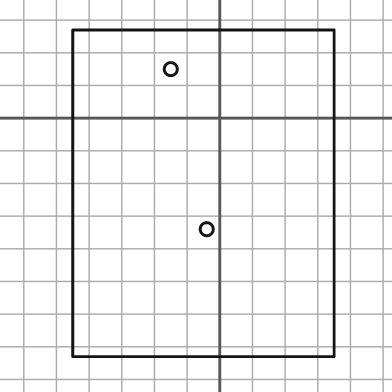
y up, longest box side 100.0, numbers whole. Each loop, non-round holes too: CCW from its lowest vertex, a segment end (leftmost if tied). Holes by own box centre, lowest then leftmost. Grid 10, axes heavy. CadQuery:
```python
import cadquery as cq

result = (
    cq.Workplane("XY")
    .moveTo(-45.0, -73.0)
    .lineTo(35.0, -73.0)
    .lineTo(35.0, 27.0)
    .lineTo(-45.0, 27.0)
    .close()
    .moveTo(-4.0, -34.0)
    .circle(2.0)
    .moveTo(-15.0, 15.0)
    .circle(2.0)
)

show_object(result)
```